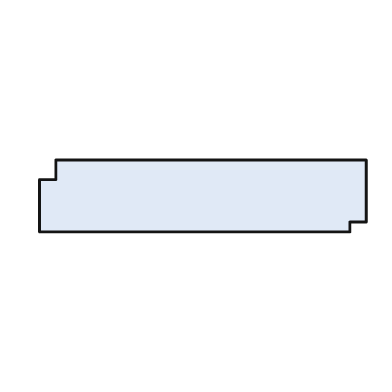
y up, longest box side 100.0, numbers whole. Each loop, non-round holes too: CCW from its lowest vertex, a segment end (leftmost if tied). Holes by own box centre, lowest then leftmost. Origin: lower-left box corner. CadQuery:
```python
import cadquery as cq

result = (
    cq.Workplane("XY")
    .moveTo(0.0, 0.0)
    .lineTo(95.0, 0.0)
    .lineTo(95.0, 3.0)
    .lineTo(100.0, 3.0)
    .lineTo(100.0, 22.0)
    .lineTo(5.0, 22.0)
    .lineTo(5.0, 16.0)
    .lineTo(0.0, 16.0)
    .close()
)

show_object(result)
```